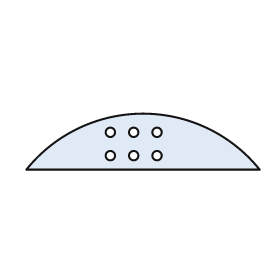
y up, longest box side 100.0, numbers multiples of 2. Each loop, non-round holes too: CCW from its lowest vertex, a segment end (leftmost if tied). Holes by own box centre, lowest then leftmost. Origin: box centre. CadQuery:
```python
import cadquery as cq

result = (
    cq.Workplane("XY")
    .moveTo(-50.0, -12.0)
    .lineTo(50.0, -12.0)
    .threePointArc((0.0, 12.0), (-50.0, -12.0))
    .close()
    .moveTo(-14.0, -6.0)
    .circle(2.0)
    .moveTo(-4.0, -6.0)
    .circle(2.0)
    .moveTo(6.0, -6.0)
    .circle(2.0)
    .moveTo(-14.0, 4.0)
    .circle(2.0)
    .moveTo(-4.0, 4.0)
    .circle(2.0)
    .moveTo(6.0, 4.0)
    .circle(2.0)
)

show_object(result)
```